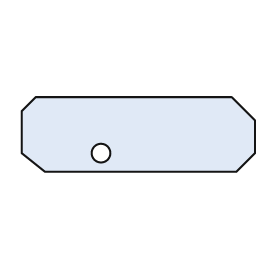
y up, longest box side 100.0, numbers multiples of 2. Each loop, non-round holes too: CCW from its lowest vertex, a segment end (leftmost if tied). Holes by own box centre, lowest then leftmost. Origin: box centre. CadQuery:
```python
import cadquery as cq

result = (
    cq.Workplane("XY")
    .moveTo(-40.0, -16.0)
    .lineTo(42.0, -16.0)
    .lineTo(50.0, -8.0)
    .lineTo(50.0, 6.0)
    .lineTo(40.0, 16.0)
    .lineTo(-44.0, 16.0)
    .lineTo(-50.0, 10.0)
    .lineTo(-50.0, -8.0)
    .close()
    .moveTo(-16.0, -8.0)
    .circle(4.0)
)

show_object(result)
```